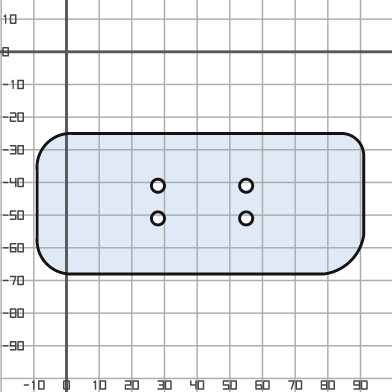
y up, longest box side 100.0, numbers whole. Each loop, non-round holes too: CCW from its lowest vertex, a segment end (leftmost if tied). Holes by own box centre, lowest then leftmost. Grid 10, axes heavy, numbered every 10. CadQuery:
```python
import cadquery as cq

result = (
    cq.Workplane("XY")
    .moveTo(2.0, -68.0)
    .lineTo(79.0, -68.0)
    .threePointArc((87.0, -64.0), (91.0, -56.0))
    .lineTo(91.0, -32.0)
    .threePointArc((89.0, -27.0), (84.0, -25.0))
    .lineTo(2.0, -25.0)
    .threePointArc((-6.0, -28.0), (-9.0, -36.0))
    .lineTo(-9.0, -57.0)
    .threePointArc((-6.0, -65.0), (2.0, -68.0))
    .close()
    .moveTo(28.0, -51.0)
    .circle(2.0)
    .moveTo(55.0, -51.0)
    .circle(2.0)
    .moveTo(28.0, -41.0)
    .circle(2.0)
    .moveTo(55.0, -41.0)
    .circle(2.0)
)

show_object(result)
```